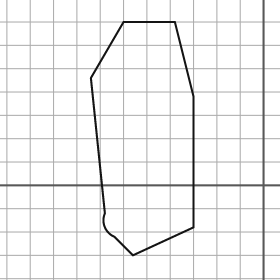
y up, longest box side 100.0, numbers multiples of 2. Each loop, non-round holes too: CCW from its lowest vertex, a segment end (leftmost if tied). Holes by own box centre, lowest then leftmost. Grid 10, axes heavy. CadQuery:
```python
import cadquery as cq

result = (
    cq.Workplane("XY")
    .moveTo(-56.0, -30.0)
    .lineTo(-30.0, -18.0)
    .lineTo(-30.0, 38.0)
    .lineTo(-38.0, 70.0)
    .lineTo(-60.0, 70.0)
    .lineTo(-74.0, 46.0)
    .lineTo(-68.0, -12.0)
    .threePointArc((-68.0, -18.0), (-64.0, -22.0))
    .close()
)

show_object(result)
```